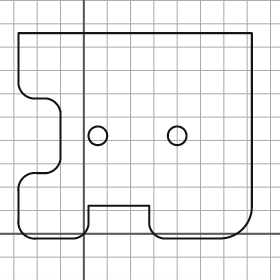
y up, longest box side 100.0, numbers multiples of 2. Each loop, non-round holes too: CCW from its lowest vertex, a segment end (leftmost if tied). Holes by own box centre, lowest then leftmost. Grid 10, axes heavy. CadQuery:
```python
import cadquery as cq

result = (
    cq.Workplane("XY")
    .moveTo(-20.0, -2.0)
    .lineTo(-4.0, -2.0)
    .threePointArc((0.0, 0.0), (2.0, 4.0))
    .lineTo(2.0, 12.0)
    .lineTo(28.0, 12.0)
    .lineTo(28.0, 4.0)
    .threePointArc((30.0, 0.0), (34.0, -2.0))
    .lineTo(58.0, -2.0)
    .threePointArc((68.0, 2.0), (72.0, 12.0))
    .lineTo(72.0, 86.0)
    .lineTo(-28.0, 86.0)
    .lineTo(-28.0, 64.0)
    .threePointArc((-26.0, 60.0), (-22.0, 58.0))
    .lineTo(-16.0, 58.0)
    .threePointArc((-12.0, 56.0), (-10.0, 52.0))
    .lineTo(-10.0, 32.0)
    .threePointArc((-12.0, 28.0), (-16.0, 26.0))
    .lineTo(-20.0, 26.0)
    .threePointArc((-26.0, 24.0), (-28.0, 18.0))
    .lineTo(-28.0, 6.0)
    .threePointArc((-26.0, 0.0), (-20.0, -2.0))
    .close()
    .moveTo(6.0, 42.0)
    .circle(4.0)
    .moveTo(40.0, 42.0)
    .circle(4.0)
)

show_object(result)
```